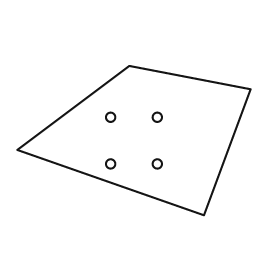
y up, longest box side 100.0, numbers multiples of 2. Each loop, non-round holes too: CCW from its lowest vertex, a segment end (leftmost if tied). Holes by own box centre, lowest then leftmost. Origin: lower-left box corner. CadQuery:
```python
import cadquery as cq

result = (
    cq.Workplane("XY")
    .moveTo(80.0, 0.0)
    .lineTo(100.0, 54.0)
    .lineTo(48.0, 64.0)
    .lineTo(0.0, 28.0)
    .close()
    .moveTo(40.0, 22.0)
    .circle(2.0)
    .moveTo(60.0, 22.0)
    .circle(2.0)
    .moveTo(40.0, 42.0)
    .circle(2.0)
    .moveTo(60.0, 42.0)
    .circle(2.0)
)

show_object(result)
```